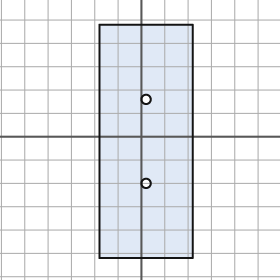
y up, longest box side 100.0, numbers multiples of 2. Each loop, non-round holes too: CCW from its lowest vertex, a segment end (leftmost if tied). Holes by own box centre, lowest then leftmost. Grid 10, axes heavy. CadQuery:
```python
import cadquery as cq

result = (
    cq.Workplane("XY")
    .moveTo(-18.0, -52.0)
    .lineTo(22.0, -52.0)
    .lineTo(22.0, 48.0)
    .lineTo(-18.0, 48.0)
    .close()
    .moveTo(2.0, -20.0)
    .circle(2.0)
    .moveTo(2.0, 16.0)
    .circle(2.0)
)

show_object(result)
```